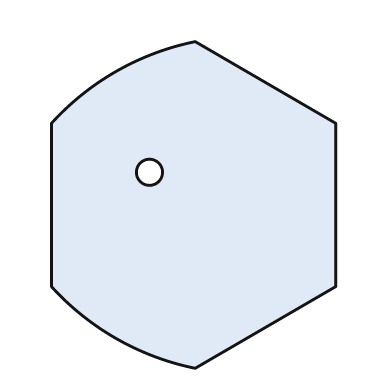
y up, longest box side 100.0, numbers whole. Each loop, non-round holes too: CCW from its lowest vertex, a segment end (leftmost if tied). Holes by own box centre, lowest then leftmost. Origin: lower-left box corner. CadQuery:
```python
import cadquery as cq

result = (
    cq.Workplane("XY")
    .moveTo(44.0, 0.0)
    .lineTo(87.0, 25.0)
    .lineTo(87.0, 75.0)
    .lineTo(44.0, 100.0)
    .threePointArc((20.0, 91.0), (0.0, 75.0))
    .lineTo(0.0, 25.0)
    .threePointArc((20.0, 9.0), (44.0, 0.0))
    .close()
    .moveTo(30.0, 60.0)
    .circle(4.0)
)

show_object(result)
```